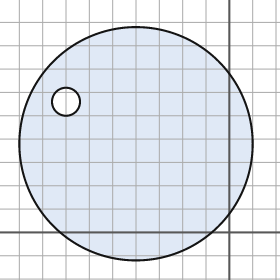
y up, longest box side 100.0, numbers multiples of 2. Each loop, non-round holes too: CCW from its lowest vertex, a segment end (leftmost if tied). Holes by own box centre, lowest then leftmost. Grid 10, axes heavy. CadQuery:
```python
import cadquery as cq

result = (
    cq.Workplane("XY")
    .moveTo(-40.0, 38.0)
    .circle(50.0)
    .moveTo(-70.0, 56.0)
    .circle(6.0)
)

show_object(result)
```